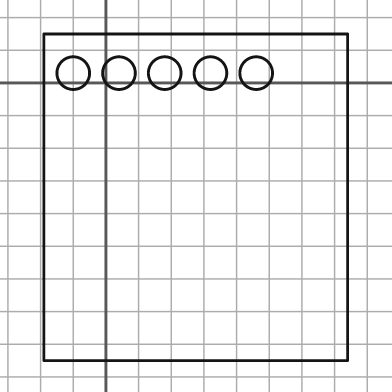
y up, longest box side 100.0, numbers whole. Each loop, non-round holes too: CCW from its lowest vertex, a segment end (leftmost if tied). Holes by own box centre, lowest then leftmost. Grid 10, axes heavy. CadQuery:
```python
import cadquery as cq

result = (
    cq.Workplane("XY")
    .moveTo(-19.0, -85.0)
    .lineTo(74.0, -85.0)
    .lineTo(74.0, 15.0)
    .lineTo(-19.0, 15.0)
    .close()
    .moveTo(-10.0, 3.0)
    .circle(5.0)
    .moveTo(4.0, 3.0)
    .circle(5.0)
    .moveTo(18.0, 3.0)
    .circle(5.0)
    .moveTo(32.0, 3.0)
    .circle(5.0)
    .moveTo(46.0, 3.0)
    .circle(5.0)
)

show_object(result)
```